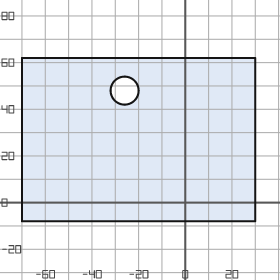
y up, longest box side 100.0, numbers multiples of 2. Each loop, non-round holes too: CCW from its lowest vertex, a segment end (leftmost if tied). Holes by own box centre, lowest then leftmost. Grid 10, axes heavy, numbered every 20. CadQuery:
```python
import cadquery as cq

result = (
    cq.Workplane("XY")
    .moveTo(-70.0, -8.0)
    .lineTo(30.0, -8.0)
    .lineTo(30.0, 62.0)
    .lineTo(-70.0, 62.0)
    .close()
    .moveTo(-26.0, 48.0)
    .circle(6.0)
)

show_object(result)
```